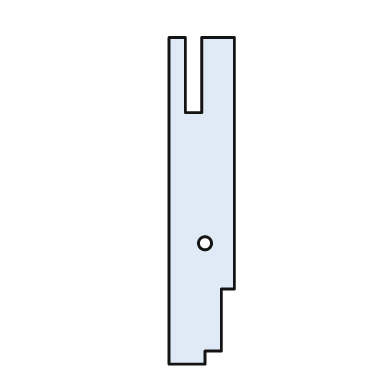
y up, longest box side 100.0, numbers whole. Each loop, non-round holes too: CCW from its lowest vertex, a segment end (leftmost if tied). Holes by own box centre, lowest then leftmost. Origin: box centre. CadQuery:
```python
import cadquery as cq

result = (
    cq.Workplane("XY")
    .moveTo(-10.0, -50.0)
    .lineTo(1.0, -50.0)
    .lineTo(1.0, -46.0)
    .lineTo(6.0, -46.0)
    .lineTo(6.0, -27.0)
    .lineTo(10.0, -27.0)
    .lineTo(10.0, 50.0)
    .lineTo(0.0, 50.0)
    .lineTo(0.0, 27.0)
    .lineTo(-5.0, 27.0)
    .lineTo(-5.0, 50.0)
    .lineTo(-10.0, 50.0)
    .close()
    .moveTo(1.0, -13.0)
    .circle(2.0)
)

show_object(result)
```